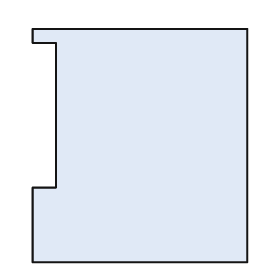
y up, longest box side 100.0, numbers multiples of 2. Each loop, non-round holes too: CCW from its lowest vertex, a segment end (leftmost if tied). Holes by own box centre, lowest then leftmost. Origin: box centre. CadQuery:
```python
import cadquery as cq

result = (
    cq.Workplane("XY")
    .moveTo(-46.0, -50.0)
    .lineTo(46.0, -50.0)
    .lineTo(46.0, 50.0)
    .lineTo(-46.0, 50.0)
    .lineTo(-46.0, 44.0)
    .lineTo(-36.0, 44.0)
    .lineTo(-36.0, -18.0)
    .lineTo(-46.0, -18.0)
    .close()
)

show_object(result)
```